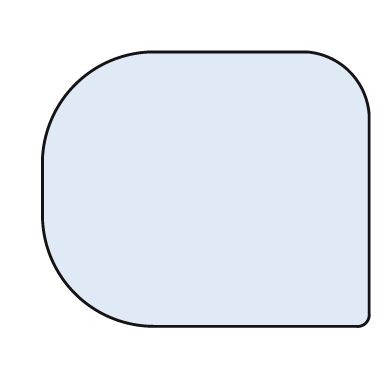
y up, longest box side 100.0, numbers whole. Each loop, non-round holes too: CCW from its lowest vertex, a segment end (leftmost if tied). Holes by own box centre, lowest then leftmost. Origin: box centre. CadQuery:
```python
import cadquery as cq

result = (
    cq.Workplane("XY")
    .moveTo(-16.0, -42.0)
    .lineTo(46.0, -42.0)
    .threePointArc((49.0, -41.0), (50.0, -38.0))
    .lineTo(50.0, 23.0)
    .threePointArc((44.0, 36.0), (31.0, 42.0))
    .lineTo(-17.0, 42.0)
    .threePointArc((-40.0, 32.0), (-50.0, 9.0))
    .lineTo(-50.0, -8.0)
    .threePointArc((-40.0, -32.0), (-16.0, -42.0))
    .close()
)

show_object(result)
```